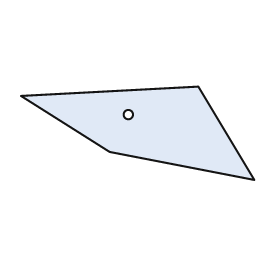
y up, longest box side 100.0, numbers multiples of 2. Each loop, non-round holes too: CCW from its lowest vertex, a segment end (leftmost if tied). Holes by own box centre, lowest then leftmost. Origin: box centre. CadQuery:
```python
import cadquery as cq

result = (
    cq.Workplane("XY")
    .moveTo(50.0, -20.0)
    .lineTo(26.0, 20.0)
    .lineTo(-50.0, 16.0)
    .lineTo(-12.0, -8.0)
    .close()
    .moveTo(-4.0, 8.0)
    .circle(2.0)
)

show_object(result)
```